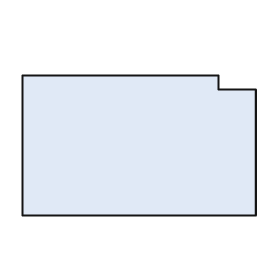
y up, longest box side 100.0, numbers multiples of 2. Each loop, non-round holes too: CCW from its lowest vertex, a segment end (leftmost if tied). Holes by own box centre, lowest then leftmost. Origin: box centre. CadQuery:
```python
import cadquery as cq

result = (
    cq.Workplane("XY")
    .moveTo(-50.0, -30.0)
    .lineTo(50.0, -30.0)
    .lineTo(50.0, 24.0)
    .lineTo(34.0, 24.0)
    .lineTo(34.0, 30.0)
    .lineTo(-50.0, 30.0)
    .close()
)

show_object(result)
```